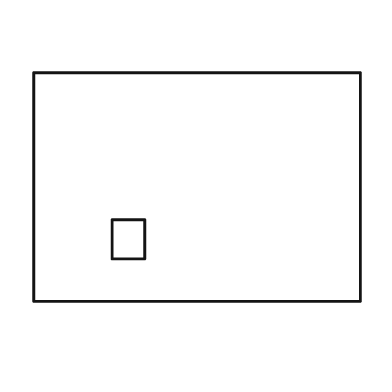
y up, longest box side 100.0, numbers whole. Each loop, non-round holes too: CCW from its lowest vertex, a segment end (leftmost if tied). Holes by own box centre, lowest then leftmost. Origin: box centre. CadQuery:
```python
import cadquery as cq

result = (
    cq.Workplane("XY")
    .moveTo(-50.0, -35.0)
    .lineTo(50.0, -35.0)
    .lineTo(50.0, 35.0)
    .lineTo(-50.0, 35.0)
    .close()
    .moveTo(-26.0, -22.0)
    .lineTo(-16.0, -22.0)
    .lineTo(-16.0, -10.0)
    .lineTo(-26.0, -10.0)
    .close()
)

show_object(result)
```